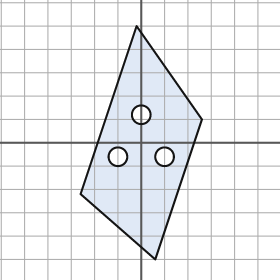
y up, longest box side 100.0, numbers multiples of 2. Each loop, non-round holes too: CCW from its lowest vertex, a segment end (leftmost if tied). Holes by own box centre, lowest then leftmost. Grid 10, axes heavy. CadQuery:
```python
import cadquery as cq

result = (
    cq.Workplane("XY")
    .moveTo(6.0, -50.0)
    .lineTo(26.0, 10.0)
    .lineTo(-2.0, 50.0)
    .lineTo(-26.0, -22.0)
    .close()
    .moveTo(-10.0, -6.0)
    .circle(4.0)
    .moveTo(10.0, -6.0)
    .circle(4.0)
    .moveTo(0.0, 12.0)
    .circle(4.0)
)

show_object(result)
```